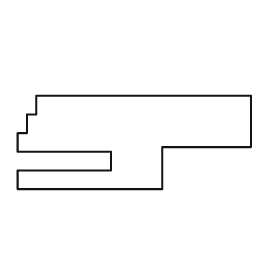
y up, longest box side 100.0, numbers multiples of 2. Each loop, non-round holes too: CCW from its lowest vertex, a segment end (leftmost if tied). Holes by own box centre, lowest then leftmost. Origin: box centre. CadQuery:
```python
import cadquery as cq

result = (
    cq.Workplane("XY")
    .moveTo(-50.0, -20.0)
    .lineTo(12.0, -20.0)
    .lineTo(12.0, -2.0)
    .lineTo(50.0, -2.0)
    .lineTo(50.0, 20.0)
    .lineTo(-42.0, 20.0)
    .lineTo(-42.0, 12.0)
    .lineTo(-46.0, 12.0)
    .lineTo(-46.0, 4.0)
    .lineTo(-50.0, 4.0)
    .lineTo(-50.0, -4.0)
    .lineTo(-10.0, -4.0)
    .lineTo(-10.0, -12.0)
    .lineTo(-50.0, -12.0)
    .close()
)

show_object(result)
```